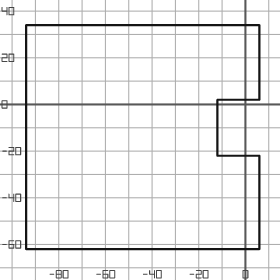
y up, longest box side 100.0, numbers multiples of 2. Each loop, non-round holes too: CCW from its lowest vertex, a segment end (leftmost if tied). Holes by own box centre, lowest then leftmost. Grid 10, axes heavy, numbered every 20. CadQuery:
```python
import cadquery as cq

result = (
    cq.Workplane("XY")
    .moveTo(-94.0, -62.0)
    .lineTo(6.0, -62.0)
    .lineTo(6.0, -22.0)
    .lineTo(-12.0, -22.0)
    .lineTo(-12.0, 2.0)
    .lineTo(6.0, 2.0)
    .lineTo(6.0, 34.0)
    .lineTo(-94.0, 34.0)
    .close()
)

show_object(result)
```